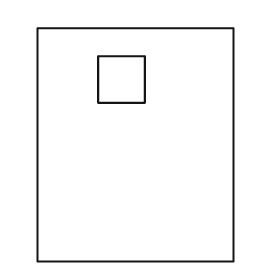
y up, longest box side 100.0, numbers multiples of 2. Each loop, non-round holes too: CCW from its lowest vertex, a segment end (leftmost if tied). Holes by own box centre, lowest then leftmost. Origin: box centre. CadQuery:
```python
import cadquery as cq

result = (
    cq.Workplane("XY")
    .moveTo(-42.0, -50.0)
    .lineTo(42.0, -50.0)
    .lineTo(42.0, 50.0)
    .lineTo(-42.0, 50.0)
    .close()
    .moveTo(-16.0, 18.0)
    .lineTo(4.0, 18.0)
    .lineTo(4.0, 38.0)
    .lineTo(-16.0, 38.0)
    .close()
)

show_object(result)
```